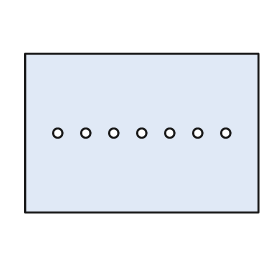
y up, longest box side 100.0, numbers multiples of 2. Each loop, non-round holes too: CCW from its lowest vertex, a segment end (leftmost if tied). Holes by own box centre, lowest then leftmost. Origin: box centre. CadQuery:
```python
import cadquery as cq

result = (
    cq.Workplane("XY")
    .moveTo(-50.0, -34.0)
    .lineTo(50.0, -34.0)
    .lineTo(50.0, 34.0)
    .lineTo(-50.0, 34.0)
    .close()
    .moveTo(-36.0, 0.0)
    .circle(2.0)
    .moveTo(-24.0, 0.0)
    .circle(2.0)
    .moveTo(-12.0, 0.0)
    .circle(2.0)
    .moveTo(0.0, 0.0)
    .circle(2.0)
    .moveTo(12.0, 0.0)
    .circle(2.0)
    .moveTo(24.0, 0.0)
    .circle(2.0)
    .moveTo(36.0, 0.0)
    .circle(2.0)
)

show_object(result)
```